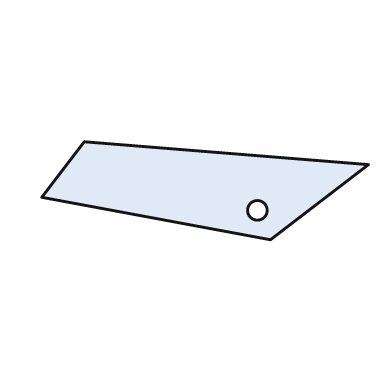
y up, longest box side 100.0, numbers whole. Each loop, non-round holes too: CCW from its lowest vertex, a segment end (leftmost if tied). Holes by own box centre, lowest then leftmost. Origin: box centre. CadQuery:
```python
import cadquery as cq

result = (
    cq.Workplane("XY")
    .moveTo(20.0, -15.0)
    .lineTo(50.0, 8.0)
    .lineTo(-37.0, 15.0)
    .lineTo(-50.0, -2.0)
    .close()
    .moveTo(16.0, -6.0)
    .circle(3.0)
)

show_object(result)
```